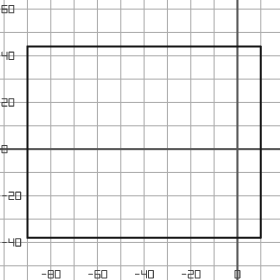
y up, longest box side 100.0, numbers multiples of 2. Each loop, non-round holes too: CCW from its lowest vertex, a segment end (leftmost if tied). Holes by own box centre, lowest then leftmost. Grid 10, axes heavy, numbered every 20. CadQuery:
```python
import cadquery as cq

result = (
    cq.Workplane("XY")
    .moveTo(-90.0, -38.0)
    .lineTo(10.0, -38.0)
    .lineTo(10.0, 44.0)
    .lineTo(-90.0, 44.0)
    .close()
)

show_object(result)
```